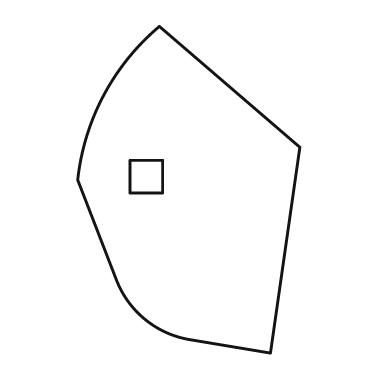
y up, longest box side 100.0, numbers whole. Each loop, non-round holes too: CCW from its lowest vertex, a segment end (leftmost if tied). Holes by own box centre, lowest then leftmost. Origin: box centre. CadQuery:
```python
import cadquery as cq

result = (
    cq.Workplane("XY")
    .moveTo(25.0, -50.0)
    .lineTo(34.0, 13.0)
    .lineTo(-9.0, 50.0)
    .threePointArc((-26.0, 29.0), (-34.0, 3.0))
    .lineTo(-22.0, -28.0)
    .threePointArc((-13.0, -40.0), (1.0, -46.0))
    .close()
    .moveTo(-18.0, -1.0)
    .lineTo(-8.0, -1.0)
    .lineTo(-8.0, 9.0)
    .lineTo(-18.0, 9.0)
    .close()
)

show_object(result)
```